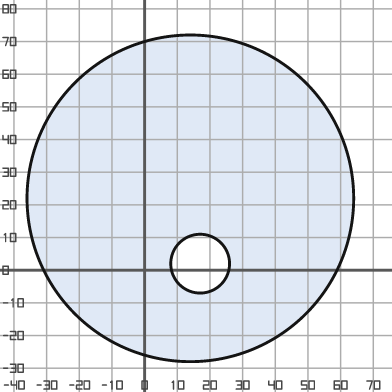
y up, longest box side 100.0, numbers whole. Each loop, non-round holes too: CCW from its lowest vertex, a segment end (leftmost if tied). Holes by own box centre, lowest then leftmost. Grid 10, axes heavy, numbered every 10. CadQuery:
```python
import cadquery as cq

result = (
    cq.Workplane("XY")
    .moveTo(14.0, 22.0)
    .circle(50.0)
    .moveTo(17.0, 2.0)
    .circle(9.0)
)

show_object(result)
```